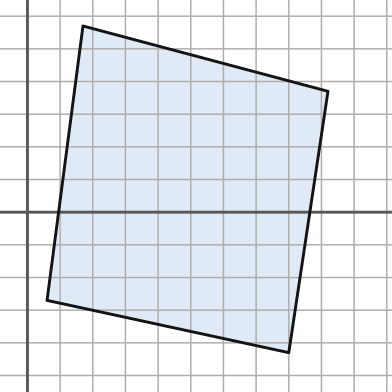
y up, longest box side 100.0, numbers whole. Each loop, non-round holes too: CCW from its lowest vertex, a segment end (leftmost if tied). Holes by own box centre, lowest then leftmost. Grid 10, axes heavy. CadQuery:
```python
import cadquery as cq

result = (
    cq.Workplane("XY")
    .moveTo(80.0, -43.0)
    .lineTo(92.0, 37.0)
    .lineTo(17.0, 57.0)
    .lineTo(6.0, -27.0)
    .close()
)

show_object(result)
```